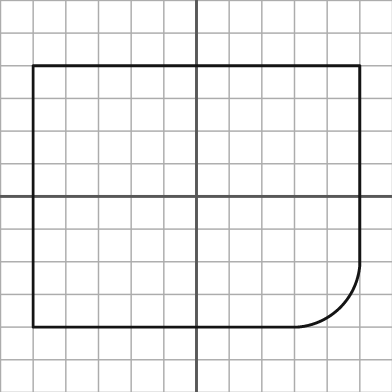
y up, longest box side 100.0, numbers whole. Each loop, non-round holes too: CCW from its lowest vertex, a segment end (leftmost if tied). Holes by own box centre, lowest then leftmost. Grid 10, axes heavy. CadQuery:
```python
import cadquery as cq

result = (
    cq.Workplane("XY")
    .moveTo(-50.0, -40.0)
    .lineTo(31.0, -40.0)
    .threePointArc((44.0, -34.0), (50.0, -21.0))
    .lineTo(50.0, 40.0)
    .lineTo(-50.0, 40.0)
    .close()
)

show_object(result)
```